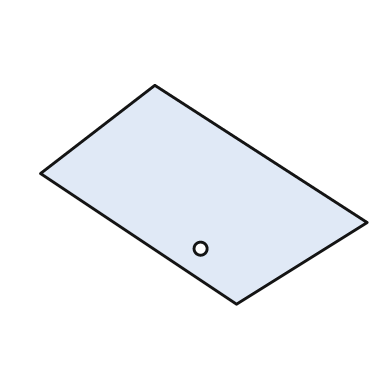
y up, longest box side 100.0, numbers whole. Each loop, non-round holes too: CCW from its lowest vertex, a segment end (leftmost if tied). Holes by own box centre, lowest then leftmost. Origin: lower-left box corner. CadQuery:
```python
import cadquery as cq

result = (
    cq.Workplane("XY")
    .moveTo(60.0, 0.0)
    .lineTo(100.0, 25.0)
    .lineTo(35.0, 67.0)
    .lineTo(0.0, 40.0)
    .close()
    .moveTo(49.0, 17.0)
    .circle(2.0)
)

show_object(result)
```